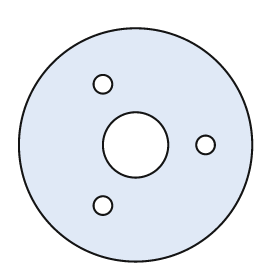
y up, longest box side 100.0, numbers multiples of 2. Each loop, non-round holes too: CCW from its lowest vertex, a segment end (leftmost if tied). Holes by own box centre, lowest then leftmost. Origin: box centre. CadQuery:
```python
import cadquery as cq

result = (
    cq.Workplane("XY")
    .moveTo(0.0, 0.0)
    .circle(50.0)
    .moveTo(-14.0, -26.0)
    .circle(4.0)
    .moveTo(0.0, 0.0)
    .circle(14.0)
    .moveTo(30.0, 0.0)
    .circle(4.0)
    .moveTo(-14.0, 26.0)
    .circle(4.0)
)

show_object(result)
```